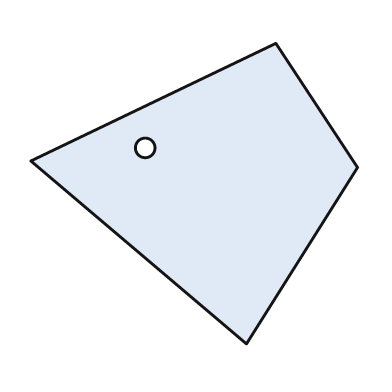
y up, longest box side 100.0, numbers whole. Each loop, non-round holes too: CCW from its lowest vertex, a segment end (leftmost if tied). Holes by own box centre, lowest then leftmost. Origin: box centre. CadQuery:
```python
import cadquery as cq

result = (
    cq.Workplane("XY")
    .moveTo(16.0, -46.0)
    .lineTo(50.0, 8.0)
    .lineTo(25.0, 46.0)
    .lineTo(-50.0, 10.0)
    .close()
    .moveTo(-15.0, 14.0)
    .circle(3.0)
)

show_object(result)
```